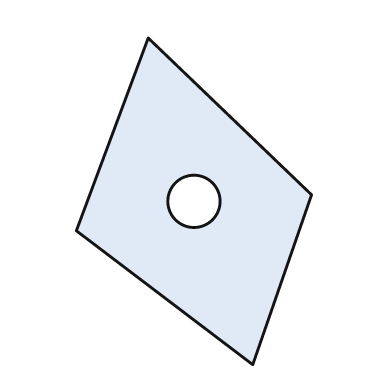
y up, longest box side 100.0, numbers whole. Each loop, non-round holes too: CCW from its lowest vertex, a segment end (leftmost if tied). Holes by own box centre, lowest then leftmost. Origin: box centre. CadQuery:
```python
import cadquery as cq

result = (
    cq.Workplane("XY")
    .moveTo(18.0, -50.0)
    .lineTo(36.0, 2.0)
    .lineTo(-14.0, 50.0)
    .lineTo(-36.0, -9.0)
    .close()
    .moveTo(0.0, 0.0)
    .circle(8.0)
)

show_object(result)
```